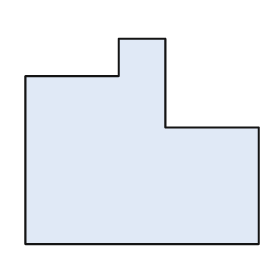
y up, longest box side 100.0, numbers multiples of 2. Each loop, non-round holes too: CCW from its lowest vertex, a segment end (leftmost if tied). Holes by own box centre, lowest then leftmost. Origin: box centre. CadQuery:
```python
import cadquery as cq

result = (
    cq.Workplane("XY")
    .moveTo(-50.0, -44.0)
    .lineTo(50.0, -44.0)
    .lineTo(50.0, 6.0)
    .lineTo(10.0, 6.0)
    .lineTo(10.0, 44.0)
    .lineTo(-10.0, 44.0)
    .lineTo(-10.0, 28.0)
    .lineTo(-50.0, 28.0)
    .close()
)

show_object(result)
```